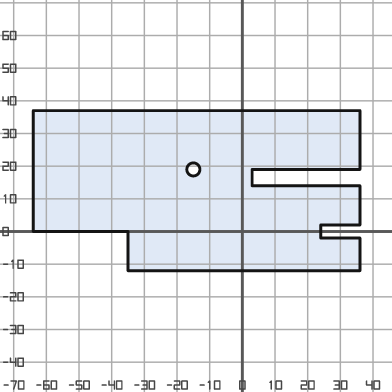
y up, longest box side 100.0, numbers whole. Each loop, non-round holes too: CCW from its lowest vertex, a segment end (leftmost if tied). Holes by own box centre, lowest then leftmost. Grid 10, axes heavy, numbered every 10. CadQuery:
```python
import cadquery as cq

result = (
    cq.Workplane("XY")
    .moveTo(-35.0, -12.0)
    .lineTo(36.0, -12.0)
    .lineTo(36.0, -2.0)
    .lineTo(24.0, -2.0)
    .lineTo(24.0, 2.0)
    .lineTo(36.0, 2.0)
    .lineTo(36.0, 14.0)
    .lineTo(3.0, 14.0)
    .lineTo(3.0, 19.0)
    .lineTo(36.0, 19.0)
    .lineTo(36.0, 37.0)
    .lineTo(-64.0, 37.0)
    .lineTo(-64.0, 0.0)
    .lineTo(-35.0, 0.0)
    .close()
    .moveTo(-15.0, 19.0)
    .circle(2.0)
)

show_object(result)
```